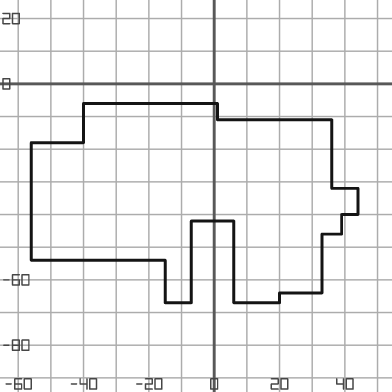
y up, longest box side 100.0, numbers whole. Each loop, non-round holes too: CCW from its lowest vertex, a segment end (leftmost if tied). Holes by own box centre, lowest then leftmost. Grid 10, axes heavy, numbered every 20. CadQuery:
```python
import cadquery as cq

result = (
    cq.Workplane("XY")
    .moveTo(-15.0, -67.0)
    .lineTo(-7.0, -67.0)
    .lineTo(-7.0, -42.0)
    .lineTo(6.0, -42.0)
    .lineTo(6.0, -67.0)
    .lineTo(20.0, -67.0)
    .lineTo(20.0, -64.0)
    .lineTo(33.0, -64.0)
    .lineTo(33.0, -46.0)
    .lineTo(39.0, -46.0)
    .lineTo(39.0, -40.0)
    .lineTo(44.0, -40.0)
    .lineTo(44.0, -32.0)
    .lineTo(36.0, -32.0)
    .lineTo(36.0, -11.0)
    .lineTo(1.0, -11.0)
    .lineTo(1.0, -6.0)
    .lineTo(-40.0, -6.0)
    .lineTo(-40.0, -18.0)
    .lineTo(-56.0, -18.0)
    .lineTo(-56.0, -54.0)
    .lineTo(-15.0, -54.0)
    .close()
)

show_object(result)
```